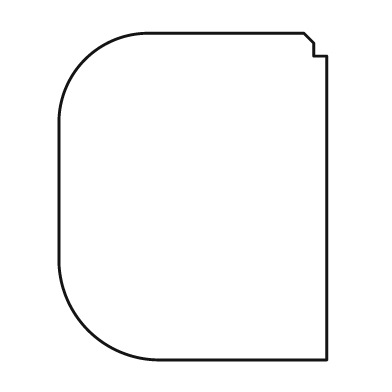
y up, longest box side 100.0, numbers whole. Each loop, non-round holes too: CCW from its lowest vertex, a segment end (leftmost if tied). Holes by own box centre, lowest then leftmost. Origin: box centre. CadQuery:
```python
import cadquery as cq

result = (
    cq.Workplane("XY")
    .moveTo(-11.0, -50.0)
    .lineTo(41.0, -50.0)
    .lineTo(41.0, 43.0)
    .lineTo(37.0, 43.0)
    .lineTo(37.0, 47.0)
    .lineTo(34.0, 50.0)
    .lineTo(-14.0, 50.0)
    .threePointArc((-33.0, 42.0), (-41.0, 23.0))
    .lineTo(-41.0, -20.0)
    .threePointArc((-32.0, -41.0), (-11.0, -50.0))
    .close()
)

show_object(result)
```